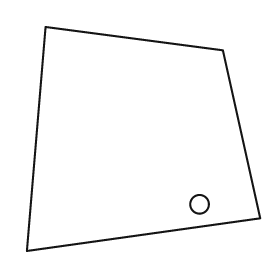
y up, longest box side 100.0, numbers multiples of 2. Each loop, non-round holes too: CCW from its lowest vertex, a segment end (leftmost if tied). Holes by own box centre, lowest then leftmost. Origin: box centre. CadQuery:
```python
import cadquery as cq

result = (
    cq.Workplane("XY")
    .moveTo(-50.0, -48.0)
    .lineTo(50.0, -34.0)
    .lineTo(34.0, 38.0)
    .lineTo(-42.0, 48.0)
    .close()
    .moveTo(24.0, -28.0)
    .circle(4.0)
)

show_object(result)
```